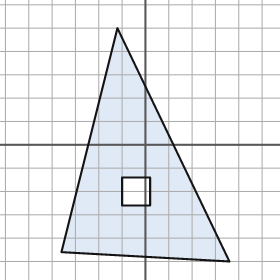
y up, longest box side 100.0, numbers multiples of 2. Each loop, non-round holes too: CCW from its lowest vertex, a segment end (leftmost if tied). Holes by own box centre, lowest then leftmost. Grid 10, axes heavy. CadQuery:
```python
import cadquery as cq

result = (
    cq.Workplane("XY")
    .moveTo(36.0, -50.0)
    .lineTo(-12.0, 50.0)
    .lineTo(-36.0, -46.0)
    .close()
    .moveTo(-10.0, -26.0)
    .lineTo(2.0, -26.0)
    .lineTo(2.0, -14.0)
    .lineTo(-10.0, -14.0)
    .close()
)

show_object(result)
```